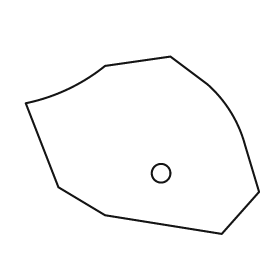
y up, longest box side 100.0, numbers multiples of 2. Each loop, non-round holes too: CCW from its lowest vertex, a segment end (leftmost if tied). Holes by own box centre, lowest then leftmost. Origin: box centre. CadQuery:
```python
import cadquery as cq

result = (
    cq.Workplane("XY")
    .moveTo(34.0, -38.0)
    .lineTo(50.0, -20.0)
    .lineTo(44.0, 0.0)
    .threePointArc((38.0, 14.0), (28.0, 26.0))
    .lineTo(12.0, 38.0)
    .lineTo(-16.0, 34.0)
    .threePointArc((-32.0, 24.0), (-50.0, 18.0))
    .lineTo(-36.0, -18.0)
    .lineTo(-16.0, -30.0)
    .close()
    .moveTo(8.0, -12.0)
    .circle(4.0)
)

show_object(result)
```